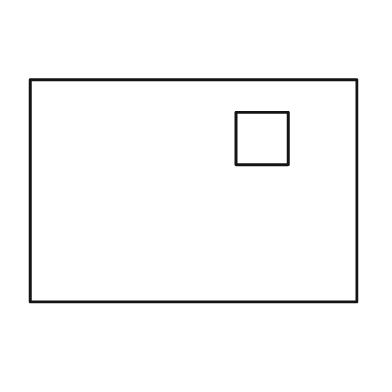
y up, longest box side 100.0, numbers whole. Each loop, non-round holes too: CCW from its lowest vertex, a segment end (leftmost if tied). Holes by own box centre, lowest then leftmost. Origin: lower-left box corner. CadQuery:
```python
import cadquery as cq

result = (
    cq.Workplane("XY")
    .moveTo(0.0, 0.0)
    .lineTo(100.0, 0.0)
    .lineTo(100.0, 68.0)
    .lineTo(0.0, 68.0)
    .close()
    .moveTo(63.0, 42.0)
    .lineTo(79.0, 42.0)
    .lineTo(79.0, 58.0)
    .lineTo(63.0, 58.0)
    .close()
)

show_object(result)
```